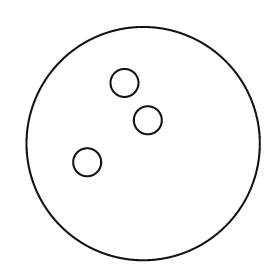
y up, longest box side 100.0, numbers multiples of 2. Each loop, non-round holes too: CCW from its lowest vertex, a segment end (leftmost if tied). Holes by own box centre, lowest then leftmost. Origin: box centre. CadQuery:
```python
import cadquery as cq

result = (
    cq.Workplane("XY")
    .moveTo(0.0, 0.0)
    .circle(50.0)
    .moveTo(-24.0, -8.0)
    .circle(6.0)
    .moveTo(2.0, 10.0)
    .circle(6.0)
    .moveTo(-8.0, 26.0)
    .circle(6.0)
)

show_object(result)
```